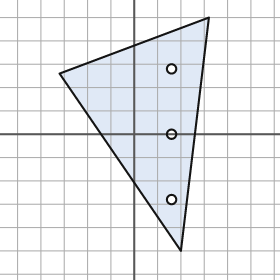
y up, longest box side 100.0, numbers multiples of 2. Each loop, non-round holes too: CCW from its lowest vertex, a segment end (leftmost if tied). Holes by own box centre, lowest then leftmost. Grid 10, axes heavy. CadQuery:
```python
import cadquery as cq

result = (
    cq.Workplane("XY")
    .moveTo(20.0, -50.0)
    .lineTo(32.0, 50.0)
    .lineTo(-32.0, 26.0)
    .close()
    .moveTo(16.0, -28.0)
    .circle(2.0)
    .moveTo(16.0, 0.0)
    .circle(2.0)
    .moveTo(16.0, 28.0)
    .circle(2.0)
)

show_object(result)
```